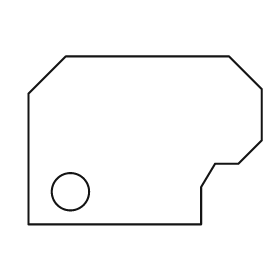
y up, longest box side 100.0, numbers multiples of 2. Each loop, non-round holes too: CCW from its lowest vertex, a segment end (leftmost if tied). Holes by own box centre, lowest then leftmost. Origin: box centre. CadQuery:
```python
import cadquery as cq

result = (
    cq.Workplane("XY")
    .moveTo(-50.0, -36.0)
    .lineTo(24.0, -36.0)
    .lineTo(24.0, -20.0)
    .lineTo(30.0, -10.0)
    .lineTo(40.0, -10.0)
    .lineTo(50.0, 0.0)
    .lineTo(50.0, 22.0)
    .lineTo(36.0, 36.0)
    .lineTo(-34.0, 36.0)
    .lineTo(-50.0, 20.0)
    .close()
    .moveTo(-32.0, -22.0)
    .circle(8.0)
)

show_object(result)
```